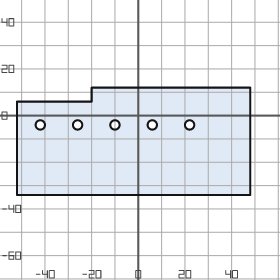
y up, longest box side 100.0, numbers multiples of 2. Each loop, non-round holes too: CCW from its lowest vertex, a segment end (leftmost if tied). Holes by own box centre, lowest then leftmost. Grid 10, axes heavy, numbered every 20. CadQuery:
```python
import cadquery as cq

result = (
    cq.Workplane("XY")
    .moveTo(-52.0, -34.0)
    .lineTo(48.0, -34.0)
    .lineTo(48.0, 12.0)
    .lineTo(-20.0, 12.0)
    .lineTo(-20.0, 6.0)
    .lineTo(-52.0, 6.0)
    .close()
    .moveTo(-42.0, -4.0)
    .circle(2.0)
    .moveTo(-26.0, -4.0)
    .circle(2.0)
    .moveTo(-10.0, -4.0)
    .circle(2.0)
    .moveTo(6.0, -4.0)
    .circle(2.0)
    .moveTo(22.0, -4.0)
    .circle(2.0)
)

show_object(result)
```